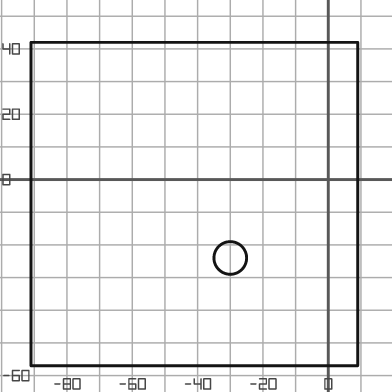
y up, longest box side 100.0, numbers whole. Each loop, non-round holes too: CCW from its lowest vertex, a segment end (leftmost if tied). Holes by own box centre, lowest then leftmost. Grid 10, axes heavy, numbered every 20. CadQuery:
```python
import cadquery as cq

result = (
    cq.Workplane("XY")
    .moveTo(-91.0, -57.0)
    .lineTo(9.0, -57.0)
    .lineTo(9.0, 42.0)
    .lineTo(-91.0, 42.0)
    .close()
    .moveTo(-30.0, -24.0)
    .circle(5.0)
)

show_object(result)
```